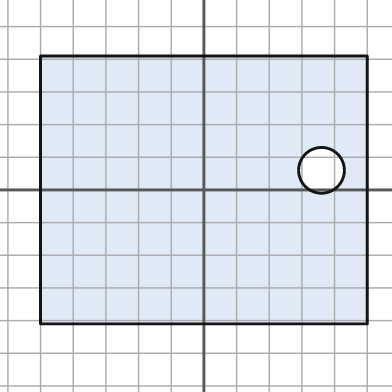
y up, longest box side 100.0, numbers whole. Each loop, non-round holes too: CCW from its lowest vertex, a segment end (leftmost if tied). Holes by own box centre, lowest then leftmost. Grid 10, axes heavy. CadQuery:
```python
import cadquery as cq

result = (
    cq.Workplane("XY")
    .moveTo(-50.0, -41.0)
    .lineTo(50.0, -41.0)
    .lineTo(50.0, 41.0)
    .lineTo(-50.0, 41.0)
    .close()
    .moveTo(36.0, 6.0)
    .circle(7.0)
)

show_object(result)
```